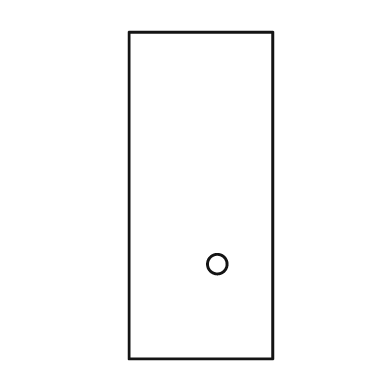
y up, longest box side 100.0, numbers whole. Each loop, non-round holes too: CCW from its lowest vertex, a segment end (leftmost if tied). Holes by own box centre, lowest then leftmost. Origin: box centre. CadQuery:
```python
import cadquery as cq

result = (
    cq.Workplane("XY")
    .moveTo(-22.0, -50.0)
    .lineTo(22.0, -50.0)
    .lineTo(22.0, 50.0)
    .lineTo(-22.0, 50.0)
    .close()
    .moveTo(5.0, -21.0)
    .circle(3.0)
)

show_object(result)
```